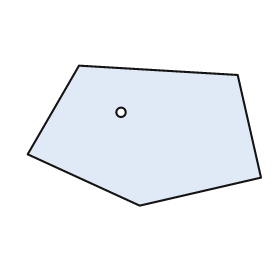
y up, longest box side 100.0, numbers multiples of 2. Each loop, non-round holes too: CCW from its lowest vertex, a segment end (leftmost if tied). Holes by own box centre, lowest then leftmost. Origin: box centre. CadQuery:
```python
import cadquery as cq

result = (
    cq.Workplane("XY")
    .moveTo(-2.0, -30.0)
    .lineTo(50.0, -18.0)
    .lineTo(40.0, 26.0)
    .lineTo(-28.0, 30.0)
    .lineTo(-50.0, -8.0)
    .close()
    .moveTo(-10.0, 10.0)
    .circle(2.0)
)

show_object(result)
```